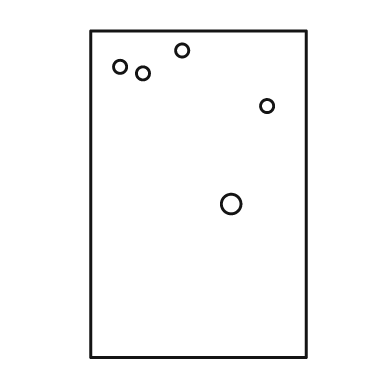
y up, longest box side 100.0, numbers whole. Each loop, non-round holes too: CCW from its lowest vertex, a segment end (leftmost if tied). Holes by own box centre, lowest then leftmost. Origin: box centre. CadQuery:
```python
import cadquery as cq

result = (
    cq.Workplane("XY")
    .moveTo(-33.0, -50.0)
    .lineTo(33.0, -50.0)
    .lineTo(33.0, 50.0)
    .lineTo(-33.0, 50.0)
    .close()
    .moveTo(10.0, -3.0)
    .circle(3.0)
    .moveTo(21.0, 27.0)
    .circle(2.0)
    .moveTo(-17.0, 37.0)
    .circle(2.0)
    .moveTo(-24.0, 39.0)
    .circle(2.0)
    .moveTo(-5.0, 44.0)
    .circle(2.0)
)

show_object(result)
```